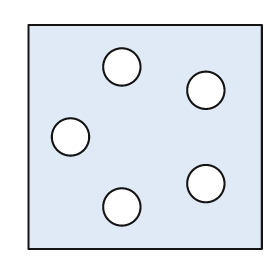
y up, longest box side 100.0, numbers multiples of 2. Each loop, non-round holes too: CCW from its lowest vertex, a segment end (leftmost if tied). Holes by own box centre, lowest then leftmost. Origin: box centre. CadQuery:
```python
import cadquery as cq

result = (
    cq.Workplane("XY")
    .moveTo(-50.0, -48.0)
    .lineTo(50.0, -48.0)
    .lineTo(50.0, 48.0)
    .lineTo(-50.0, 48.0)
    .close()
    .moveTo(-10.0, -30.0)
    .circle(8.0)
    .moveTo(26.0, -20.0)
    .circle(8.0)
    .moveTo(-32.0, 0.0)
    .circle(8.0)
    .moveTo(26.0, 20.0)
    .circle(8.0)
    .moveTo(-10.0, 30.0)
    .circle(8.0)
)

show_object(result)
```